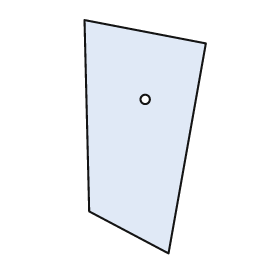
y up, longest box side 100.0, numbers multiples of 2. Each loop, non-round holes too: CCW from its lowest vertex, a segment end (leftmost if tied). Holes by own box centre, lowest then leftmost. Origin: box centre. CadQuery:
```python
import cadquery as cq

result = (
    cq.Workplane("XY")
    .moveTo(10.0, -50.0)
    .lineTo(26.0, 40.0)
    .lineTo(-26.0, 50.0)
    .lineTo(-24.0, -32.0)
    .close()
    .moveTo(0.0, 16.0)
    .circle(2.0)
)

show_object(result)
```